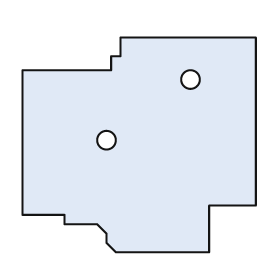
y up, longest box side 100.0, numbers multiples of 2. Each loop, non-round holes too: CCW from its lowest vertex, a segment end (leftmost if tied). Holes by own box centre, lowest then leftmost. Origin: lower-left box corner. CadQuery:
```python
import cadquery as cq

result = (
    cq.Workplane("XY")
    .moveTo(40.0, 0.0)
    .lineTo(80.0, 0.0)
    .lineTo(80.0, 20.0)
    .lineTo(100.0, 20.0)
    .lineTo(100.0, 92.0)
    .lineTo(42.0, 92.0)
    .lineTo(42.0, 84.0)
    .lineTo(38.0, 84.0)
    .lineTo(38.0, 78.0)
    .lineTo(0.0, 78.0)
    .lineTo(0.0, 16.0)
    .lineTo(18.0, 16.0)
    .lineTo(18.0, 12.0)
    .lineTo(32.0, 12.0)
    .lineTo(36.0, 8.0)
    .lineTo(36.0, 4.0)
    .close()
    .moveTo(36.0, 48.0)
    .circle(4.0)
    .moveTo(72.0, 74.0)
    .circle(4.0)
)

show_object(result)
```